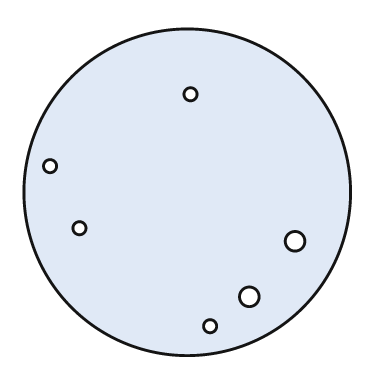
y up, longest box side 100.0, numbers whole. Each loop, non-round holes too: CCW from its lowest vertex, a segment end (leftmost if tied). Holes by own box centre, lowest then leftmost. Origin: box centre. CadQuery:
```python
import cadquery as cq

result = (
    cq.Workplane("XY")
    .moveTo(0.0, 0.0)
    .circle(50.0)
    .moveTo(7.0, -41.0)
    .circle(2.0)
    .moveTo(19.0, -32.0)
    .circle(3.0)
    .moveTo(33.0, -15.0)
    .circle(3.0)
    .moveTo(-33.0, -11.0)
    .circle(2.0)
    .moveTo(-42.0, 8.0)
    .circle(2.0)
    .moveTo(1.0, 30.0)
    .circle(2.0)
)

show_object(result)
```